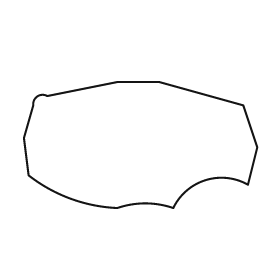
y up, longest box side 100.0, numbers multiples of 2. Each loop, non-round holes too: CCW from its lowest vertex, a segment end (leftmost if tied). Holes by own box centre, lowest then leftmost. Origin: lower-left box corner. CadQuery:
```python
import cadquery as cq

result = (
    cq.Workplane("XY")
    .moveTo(40.0, 0.0)
    .threePointArc((52.0, 2.0), (64.0, 0.0))
    .threePointArc((78.0, 12.0), (96.0, 10.0))
    .lineTo(100.0, 26.0)
    .lineTo(94.0, 44.0)
    .lineTo(58.0, 54.0)
    .lineTo(40.0, 54.0)
    .lineTo(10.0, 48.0)
    .threePointArc((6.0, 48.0), (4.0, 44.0))
    .lineTo(0.0, 30.0)
    .lineTo(2.0, 14.0)
    .threePointArc((20.0, 4.0), (40.0, 0.0))
    .close()
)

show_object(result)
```